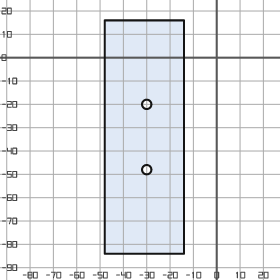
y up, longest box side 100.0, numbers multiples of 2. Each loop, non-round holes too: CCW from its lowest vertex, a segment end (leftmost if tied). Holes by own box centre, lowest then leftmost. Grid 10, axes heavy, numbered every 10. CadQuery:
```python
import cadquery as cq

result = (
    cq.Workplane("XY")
    .moveTo(-48.0, -84.0)
    .lineTo(-14.0, -84.0)
    .lineTo(-14.0, 16.0)
    .lineTo(-48.0, 16.0)
    .close()
    .moveTo(-30.0, -48.0)
    .circle(2.0)
    .moveTo(-30.0, -20.0)
    .circle(2.0)
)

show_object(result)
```